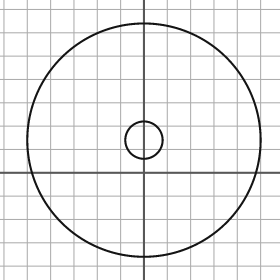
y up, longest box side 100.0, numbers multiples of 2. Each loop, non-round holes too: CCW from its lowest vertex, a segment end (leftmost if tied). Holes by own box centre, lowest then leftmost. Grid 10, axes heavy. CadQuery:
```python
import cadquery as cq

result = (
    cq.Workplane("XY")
    .moveTo(0.0, 14.0)
    .circle(50.0)
    .moveTo(0.0, 14.0)
    .circle(8.0)
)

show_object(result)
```